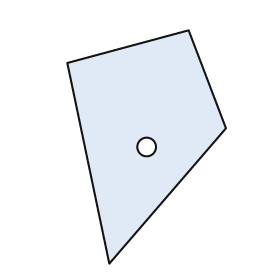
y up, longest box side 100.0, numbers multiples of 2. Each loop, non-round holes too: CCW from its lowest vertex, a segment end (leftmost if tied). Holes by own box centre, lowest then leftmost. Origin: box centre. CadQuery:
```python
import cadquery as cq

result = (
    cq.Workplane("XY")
    .moveTo(-16.0, -50.0)
    .lineTo(34.0, 8.0)
    .lineTo(18.0, 50.0)
    .lineTo(-34.0, 36.0)
    .close()
    .moveTo(0.0, 0.0)
    .circle(4.0)
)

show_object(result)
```